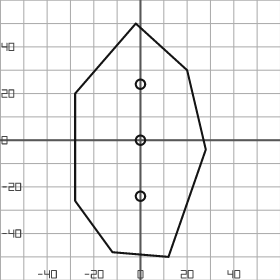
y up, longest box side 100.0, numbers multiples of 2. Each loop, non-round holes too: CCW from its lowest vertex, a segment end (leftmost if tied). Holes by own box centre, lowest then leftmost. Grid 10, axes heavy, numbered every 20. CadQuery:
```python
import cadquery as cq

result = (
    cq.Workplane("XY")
    .moveTo(12.0, -50.0)
    .lineTo(28.0, -4.0)
    .lineTo(20.0, 30.0)
    .lineTo(-2.0, 50.0)
    .lineTo(-28.0, 20.0)
    .lineTo(-28.0, -26.0)
    .lineTo(-12.0, -48.0)
    .close()
    .moveTo(0.0, -24.0)
    .circle(2.0)
    .moveTo(0.0, 0.0)
    .circle(2.0)
    .moveTo(0.0, 24.0)
    .circle(2.0)
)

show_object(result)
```